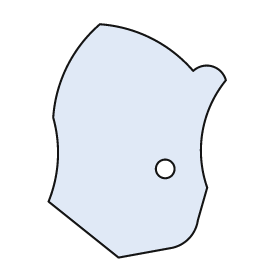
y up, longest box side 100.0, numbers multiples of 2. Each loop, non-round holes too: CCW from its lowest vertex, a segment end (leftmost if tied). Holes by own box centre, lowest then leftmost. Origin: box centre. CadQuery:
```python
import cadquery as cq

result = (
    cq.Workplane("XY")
    .moveTo(-8.0, -50.0)
    .lineTo(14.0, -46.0)
    .threePointArc((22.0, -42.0), (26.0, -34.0))
    .lineTo(30.0, -20.0)
    .threePointArc((28.0, 4.0), (38.0, 26.0))
    .threePointArc((32.0, 32.0), (24.0, 30.0))
    .threePointArc((6.0, 44.0), (-16.0, 50.0))
    .threePointArc((-30.0, 32.0), (-36.0, 10.0))
    .threePointArc((-34.0, -8.0), (-38.0, -26.0))
    .close()
    .moveTo(12.0, -12.0)
    .circle(4.0)
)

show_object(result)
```